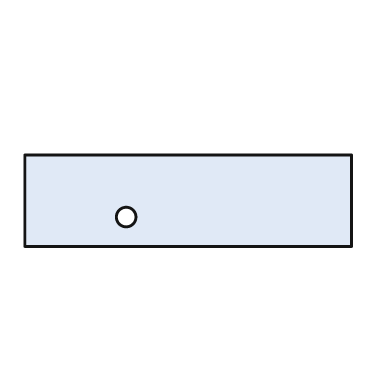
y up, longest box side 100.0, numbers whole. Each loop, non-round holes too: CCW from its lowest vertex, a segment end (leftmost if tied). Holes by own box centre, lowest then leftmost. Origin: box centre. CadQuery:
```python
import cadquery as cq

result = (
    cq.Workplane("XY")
    .moveTo(-50.0, -14.0)
    .lineTo(50.0, -14.0)
    .lineTo(50.0, 14.0)
    .lineTo(-50.0, 14.0)
    .close()
    .moveTo(-19.0, -5.0)
    .circle(3.0)
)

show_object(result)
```